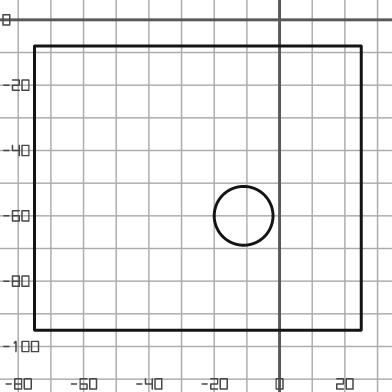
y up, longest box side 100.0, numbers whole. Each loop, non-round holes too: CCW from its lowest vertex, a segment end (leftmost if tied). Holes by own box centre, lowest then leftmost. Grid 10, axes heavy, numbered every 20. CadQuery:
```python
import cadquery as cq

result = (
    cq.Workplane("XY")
    .moveTo(-75.0, -95.0)
    .lineTo(25.0, -95.0)
    .lineTo(25.0, -8.0)
    .lineTo(-75.0, -8.0)
    .close()
    .moveTo(-11.0, -60.0)
    .circle(9.0)
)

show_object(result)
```